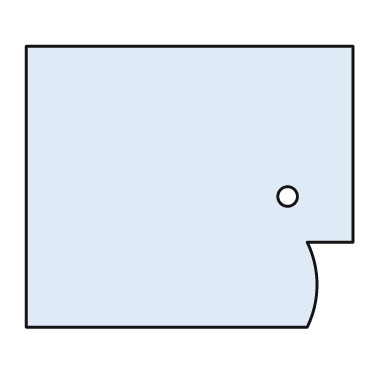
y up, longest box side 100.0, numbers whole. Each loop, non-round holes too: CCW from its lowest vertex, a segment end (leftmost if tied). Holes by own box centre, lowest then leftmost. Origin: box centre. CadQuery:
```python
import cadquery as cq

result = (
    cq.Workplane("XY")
    .moveTo(-50.0, -43.0)
    .lineTo(36.0, -43.0)
    .threePointArc((39.0, -30.0), (36.0, -17.0))
    .lineTo(50.0, -17.0)
    .lineTo(50.0, 43.0)
    .lineTo(-50.0, 43.0)
    .close()
    .moveTo(30.0, -3.0)
    .circle(3.0)
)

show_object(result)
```